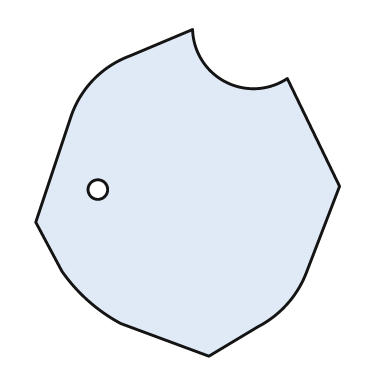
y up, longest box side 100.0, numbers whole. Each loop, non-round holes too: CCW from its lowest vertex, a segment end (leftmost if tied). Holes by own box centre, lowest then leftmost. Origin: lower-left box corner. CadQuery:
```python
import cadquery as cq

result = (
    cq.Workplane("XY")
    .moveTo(53.0, 0.0)
    .lineTo(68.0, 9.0)
    .threePointArc((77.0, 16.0), (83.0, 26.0))
    .lineTo(93.0, 52.0)
    .lineTo(77.0, 85.0)
    .threePointArc((58.0, 84.0), (48.0, 100.0))
    .lineTo(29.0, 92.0)
    .threePointArc((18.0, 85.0), (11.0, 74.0))
    .lineTo(0.0, 41.0)
    .lineTo(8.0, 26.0)
    .threePointArc((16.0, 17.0), (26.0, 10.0))
    .close()
    .moveTo(19.0, 51.0)
    .circle(3.0)
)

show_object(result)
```